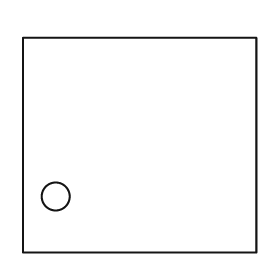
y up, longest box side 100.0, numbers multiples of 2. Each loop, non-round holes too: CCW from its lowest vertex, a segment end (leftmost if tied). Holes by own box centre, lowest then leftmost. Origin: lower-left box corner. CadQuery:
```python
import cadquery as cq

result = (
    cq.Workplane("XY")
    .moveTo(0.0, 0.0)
    .lineTo(100.0, 0.0)
    .lineTo(100.0, 92.0)
    .lineTo(0.0, 92.0)
    .close()
    .moveTo(14.0, 24.0)
    .circle(6.0)
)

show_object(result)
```